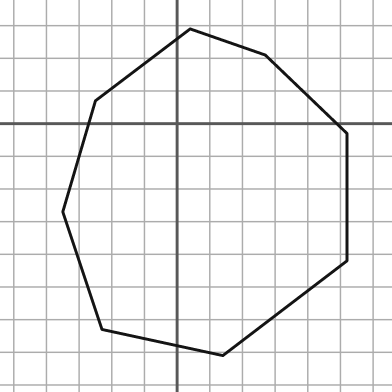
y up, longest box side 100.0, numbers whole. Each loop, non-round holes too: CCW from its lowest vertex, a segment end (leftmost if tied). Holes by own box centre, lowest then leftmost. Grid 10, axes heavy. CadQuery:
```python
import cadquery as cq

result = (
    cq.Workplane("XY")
    .moveTo(14.0, -71.0)
    .lineTo(52.0, -42.0)
    .lineTo(52.0, -3.0)
    .lineTo(27.0, 21.0)
    .lineTo(4.0, 29.0)
    .lineTo(-25.0, 7.0)
    .lineTo(-35.0, -27.0)
    .lineTo(-23.0, -63.0)
    .close()
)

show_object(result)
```